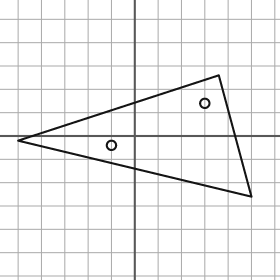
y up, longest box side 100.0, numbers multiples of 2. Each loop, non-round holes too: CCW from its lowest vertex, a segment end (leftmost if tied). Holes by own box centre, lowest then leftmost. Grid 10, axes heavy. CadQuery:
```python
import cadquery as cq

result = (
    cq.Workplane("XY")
    .moveTo(50.0, -26.0)
    .lineTo(36.0, 26.0)
    .lineTo(-50.0, -2.0)
    .close()
    .moveTo(-10.0, -4.0)
    .circle(2.0)
    .moveTo(30.0, 14.0)
    .circle(2.0)
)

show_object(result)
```